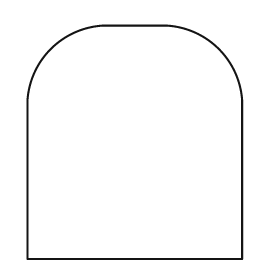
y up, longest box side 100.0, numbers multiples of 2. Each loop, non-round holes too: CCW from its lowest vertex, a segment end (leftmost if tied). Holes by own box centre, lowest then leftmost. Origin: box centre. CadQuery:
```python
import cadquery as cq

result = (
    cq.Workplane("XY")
    .moveTo(-46.0, -50.0)
    .lineTo(46.0, -50.0)
    .lineTo(46.0, 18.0)
    .threePointArc((36.0, 40.0), (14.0, 50.0))
    .lineTo(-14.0, 50.0)
    .threePointArc((-36.0, 40.0), (-46.0, 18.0))
    .close()
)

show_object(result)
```